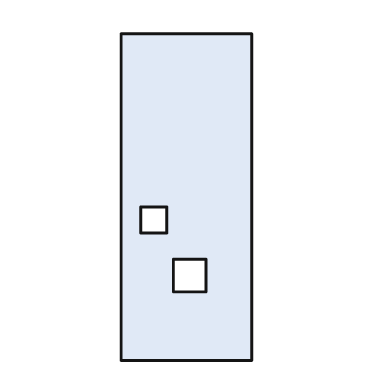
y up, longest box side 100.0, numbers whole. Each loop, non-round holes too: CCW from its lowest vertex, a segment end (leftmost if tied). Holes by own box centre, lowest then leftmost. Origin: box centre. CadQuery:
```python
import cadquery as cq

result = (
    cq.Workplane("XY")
    .moveTo(-20.0, -50.0)
    .lineTo(20.0, -50.0)
    .lineTo(20.0, 50.0)
    .lineTo(-20.0, 50.0)
    .close()
    .moveTo(-4.0, -29.0)
    .lineTo(6.0, -29.0)
    .lineTo(6.0, -19.0)
    .lineTo(-4.0, -19.0)
    .close()
    .moveTo(-14.0, -11.0)
    .lineTo(-6.0, -11.0)
    .lineTo(-6.0, -3.0)
    .lineTo(-14.0, -3.0)
    .close()
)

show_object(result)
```